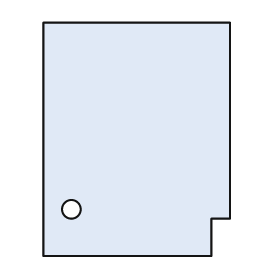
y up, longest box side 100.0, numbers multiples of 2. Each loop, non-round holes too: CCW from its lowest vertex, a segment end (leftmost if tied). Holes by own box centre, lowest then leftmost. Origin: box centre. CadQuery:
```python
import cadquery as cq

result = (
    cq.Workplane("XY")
    .moveTo(-40.0, -50.0)
    .lineTo(32.0, -50.0)
    .lineTo(32.0, -34.0)
    .lineTo(40.0, -34.0)
    .lineTo(40.0, 50.0)
    .lineTo(-40.0, 50.0)
    .close()
    .moveTo(-28.0, -30.0)
    .circle(4.0)
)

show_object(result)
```